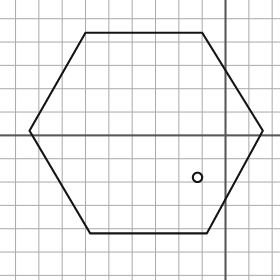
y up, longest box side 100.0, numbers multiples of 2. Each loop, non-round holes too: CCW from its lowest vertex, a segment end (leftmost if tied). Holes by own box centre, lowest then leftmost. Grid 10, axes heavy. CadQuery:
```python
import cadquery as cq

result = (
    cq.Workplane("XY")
    .moveTo(-58.0, -42.0)
    .lineTo(-8.0, -42.0)
    .lineTo(16.0, 2.0)
    .lineTo(-10.0, 44.0)
    .lineTo(-60.0, 44.0)
    .lineTo(-84.0, 2.0)
    .close()
    .moveTo(-12.0, -18.0)
    .circle(2.0)
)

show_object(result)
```